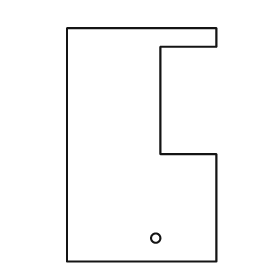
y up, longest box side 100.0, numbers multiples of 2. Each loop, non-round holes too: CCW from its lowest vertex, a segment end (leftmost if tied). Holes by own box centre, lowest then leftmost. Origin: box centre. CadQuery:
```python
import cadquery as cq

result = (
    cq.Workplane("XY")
    .moveTo(-32.0, -50.0)
    .lineTo(32.0, -50.0)
    .lineTo(32.0, -4.0)
    .lineTo(8.0, -4.0)
    .lineTo(8.0, 42.0)
    .lineTo(32.0, 42.0)
    .lineTo(32.0, 50.0)
    .lineTo(-32.0, 50.0)
    .close()
    .moveTo(6.0, -40.0)
    .circle(2.0)
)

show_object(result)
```